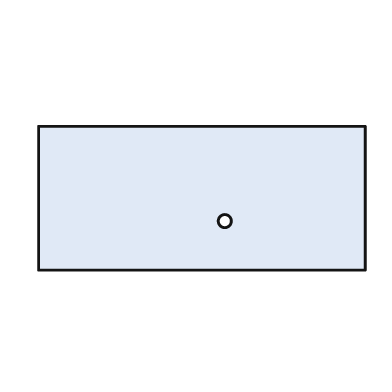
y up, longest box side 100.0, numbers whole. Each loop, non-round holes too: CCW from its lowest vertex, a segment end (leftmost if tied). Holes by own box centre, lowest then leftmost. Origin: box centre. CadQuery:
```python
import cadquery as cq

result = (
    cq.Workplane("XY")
    .moveTo(-50.0, -22.0)
    .lineTo(50.0, -22.0)
    .lineTo(50.0, 22.0)
    .lineTo(-50.0, 22.0)
    .close()
    .moveTo(7.0, -7.0)
    .circle(2.0)
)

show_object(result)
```